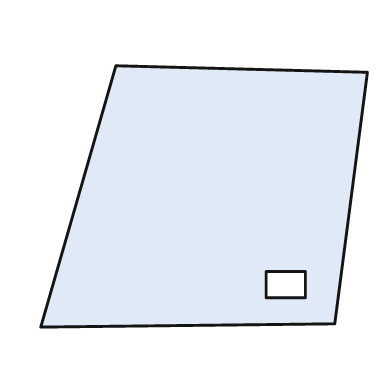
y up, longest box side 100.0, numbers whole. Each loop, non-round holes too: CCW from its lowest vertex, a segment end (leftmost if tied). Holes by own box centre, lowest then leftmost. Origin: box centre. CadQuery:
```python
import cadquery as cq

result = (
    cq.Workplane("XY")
    .moveTo(-50.0, -40.0)
    .lineTo(40.0, -39.0)
    .lineTo(50.0, 38.0)
    .lineTo(-27.0, 40.0)
    .close()
    .moveTo(19.0, -31.0)
    .lineTo(31.0, -31.0)
    .lineTo(31.0, -23.0)
    .lineTo(19.0, -23.0)
    .close()
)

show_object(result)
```